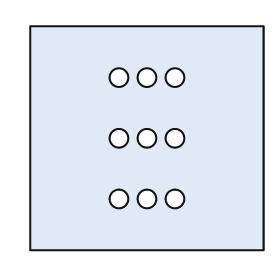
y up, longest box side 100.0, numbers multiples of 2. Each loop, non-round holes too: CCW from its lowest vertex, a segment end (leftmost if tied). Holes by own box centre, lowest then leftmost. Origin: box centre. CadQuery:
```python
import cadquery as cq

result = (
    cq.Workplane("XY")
    .moveTo(-50.0, -48.0)
    .lineTo(50.0, -48.0)
    .lineTo(50.0, 48.0)
    .lineTo(-50.0, 48.0)
    .close()
    .moveTo(-12.0, -26.0)
    .circle(4.0)
    .moveTo(0.0, -26.0)
    .circle(4.0)
    .moveTo(12.0, -26.0)
    .circle(4.0)
    .moveTo(-12.0, 0.0)
    .circle(4.0)
    .moveTo(0.0, 0.0)
    .circle(4.0)
    .moveTo(12.0, 0.0)
    .circle(4.0)
    .moveTo(-12.0, 26.0)
    .circle(4.0)
    .moveTo(0.0, 26.0)
    .circle(4.0)
    .moveTo(12.0, 26.0)
    .circle(4.0)
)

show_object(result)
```